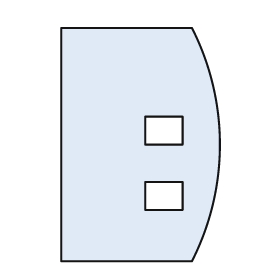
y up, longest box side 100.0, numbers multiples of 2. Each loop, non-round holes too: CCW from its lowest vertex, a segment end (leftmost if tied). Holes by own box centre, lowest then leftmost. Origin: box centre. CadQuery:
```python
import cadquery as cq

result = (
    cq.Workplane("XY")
    .moveTo(-34.0, -50.0)
    .lineTo(22.0, -50.0)
    .threePointArc((34.0, 0.0), (22.0, 50.0))
    .lineTo(-34.0, 50.0)
    .close()
    .moveTo(2.0, -28.0)
    .lineTo(18.0, -28.0)
    .lineTo(18.0, -16.0)
    .lineTo(2.0, -16.0)
    .close()
    .moveTo(2.0, 0.0)
    .lineTo(18.0, 0.0)
    .lineTo(18.0, 12.0)
    .lineTo(2.0, 12.0)
    .close()
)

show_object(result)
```